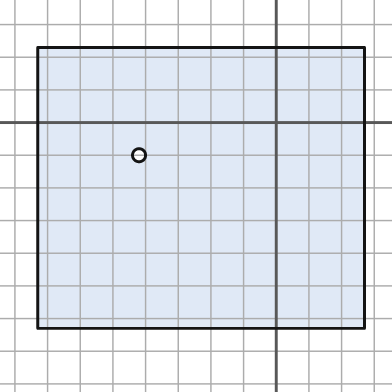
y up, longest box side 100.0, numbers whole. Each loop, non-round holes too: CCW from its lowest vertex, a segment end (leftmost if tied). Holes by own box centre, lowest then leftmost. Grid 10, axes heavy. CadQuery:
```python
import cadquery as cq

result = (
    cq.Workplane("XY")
    .moveTo(-73.0, -63.0)
    .lineTo(27.0, -63.0)
    .lineTo(27.0, 23.0)
    .lineTo(-73.0, 23.0)
    .close()
    .moveTo(-42.0, -10.0)
    .circle(2.0)
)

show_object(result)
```